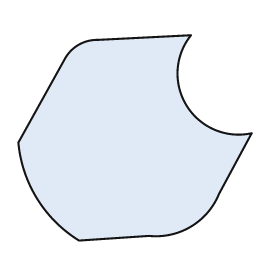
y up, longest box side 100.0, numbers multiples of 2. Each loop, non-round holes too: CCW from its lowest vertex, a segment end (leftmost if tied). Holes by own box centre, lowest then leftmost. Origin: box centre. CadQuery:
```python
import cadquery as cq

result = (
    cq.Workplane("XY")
    .moveTo(-24.0, -44.0)
    .lineTo(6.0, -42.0)
    .threePointArc((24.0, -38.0), (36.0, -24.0))
    .lineTo(50.0, 2.0)
    .threePointArc((22.0, 14.0), (24.0, 44.0))
    .lineTo(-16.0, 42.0)
    .threePointArc((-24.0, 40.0), (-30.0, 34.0))
    .lineTo(-50.0, -2.0)
    .threePointArc((-42.0, -26.0), (-24.0, -44.0))
    .close()
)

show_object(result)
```